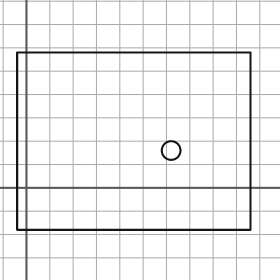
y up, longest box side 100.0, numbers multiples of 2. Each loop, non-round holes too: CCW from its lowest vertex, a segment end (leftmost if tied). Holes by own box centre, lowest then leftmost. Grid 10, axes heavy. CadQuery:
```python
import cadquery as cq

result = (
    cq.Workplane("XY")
    .moveTo(-4.0, -18.0)
    .lineTo(96.0, -18.0)
    .lineTo(96.0, 58.0)
    .lineTo(-4.0, 58.0)
    .close()
    .moveTo(62.0, 16.0)
    .circle(4.0)
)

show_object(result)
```